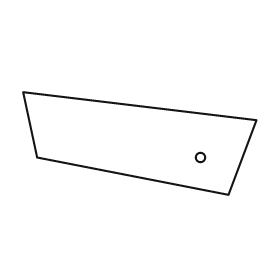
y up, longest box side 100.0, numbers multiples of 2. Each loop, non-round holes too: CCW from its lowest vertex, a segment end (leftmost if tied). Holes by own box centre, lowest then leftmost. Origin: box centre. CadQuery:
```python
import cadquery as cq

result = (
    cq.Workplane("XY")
    .moveTo(38.0, -22.0)
    .lineTo(50.0, 10.0)
    .lineTo(-50.0, 22.0)
    .lineTo(-44.0, -6.0)
    .close()
    .moveTo(26.0, -6.0)
    .circle(2.0)
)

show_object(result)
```